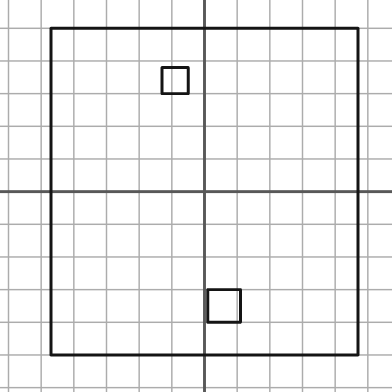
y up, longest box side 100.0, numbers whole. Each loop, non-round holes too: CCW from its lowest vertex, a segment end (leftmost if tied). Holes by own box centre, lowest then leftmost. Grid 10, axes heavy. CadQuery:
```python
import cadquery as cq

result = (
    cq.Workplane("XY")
    .moveTo(-47.0, -50.0)
    .lineTo(47.0, -50.0)
    .lineTo(47.0, 50.0)
    .lineTo(-47.0, 50.0)
    .close()
    .moveTo(1.0, -40.0)
    .lineTo(11.0, -40.0)
    .lineTo(11.0, -30.0)
    .lineTo(1.0, -30.0)
    .close()
    .moveTo(-13.0, 30.0)
    .lineTo(-5.0, 30.0)
    .lineTo(-5.0, 38.0)
    .lineTo(-13.0, 38.0)
    .close()
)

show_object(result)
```